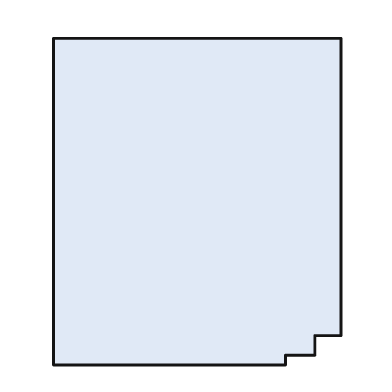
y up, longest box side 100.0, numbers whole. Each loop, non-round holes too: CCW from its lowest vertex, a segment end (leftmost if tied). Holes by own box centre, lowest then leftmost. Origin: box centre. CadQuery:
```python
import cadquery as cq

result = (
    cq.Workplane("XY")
    .moveTo(-44.0, -50.0)
    .lineTo(27.0, -50.0)
    .lineTo(27.0, -47.0)
    .lineTo(36.0, -47.0)
    .lineTo(36.0, -41.0)
    .lineTo(44.0, -41.0)
    .lineTo(44.0, 50.0)
    .lineTo(-44.0, 50.0)
    .close()
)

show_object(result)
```